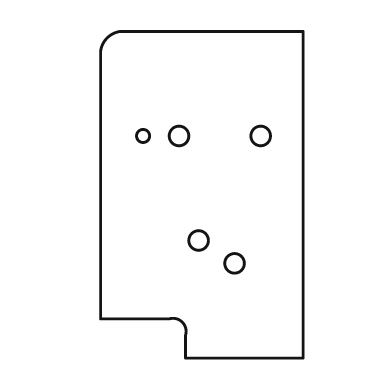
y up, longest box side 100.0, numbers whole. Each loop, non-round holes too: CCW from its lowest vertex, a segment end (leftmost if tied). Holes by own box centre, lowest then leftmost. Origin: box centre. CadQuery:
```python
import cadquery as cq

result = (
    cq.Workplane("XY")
    .moveTo(-5.0, -50.0)
    .lineTo(31.0, -50.0)
    .lineTo(31.0, 50.0)
    .lineTo(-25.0, 50.0)
    .threePointArc((-29.0, 48.0), (-31.0, 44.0))
    .lineTo(-31.0, -38.0)
    .lineTo(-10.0, -38.0)
    .threePointArc((-6.0, -39.0), (-5.0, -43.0))
    .close()
    .moveTo(10.0, -21.0)
    .circle(3.0)
    .moveTo(-1.0, -14.0)
    .circle(3.0)
    .moveTo(-18.0, 18.0)
    .circle(2.0)
    .moveTo(-7.0, 18.0)
    .circle(3.0)
    .moveTo(18.0, 18.0)
    .circle(3.0)
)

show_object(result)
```